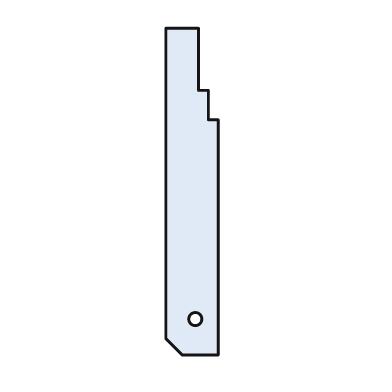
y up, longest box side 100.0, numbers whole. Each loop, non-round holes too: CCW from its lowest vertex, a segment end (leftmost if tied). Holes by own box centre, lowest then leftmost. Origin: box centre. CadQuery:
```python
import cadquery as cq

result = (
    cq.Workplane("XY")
    .moveTo(-3.0, -50.0)
    .lineTo(8.0, -50.0)
    .lineTo(8.0, 22.0)
    .lineTo(5.0, 22.0)
    .lineTo(5.0, 31.0)
    .lineTo(2.0, 31.0)
    .lineTo(2.0, 50.0)
    .lineTo(-8.0, 50.0)
    .lineTo(-8.0, -45.0)
    .close()
    .moveTo(1.0, -39.0)
    .circle(2.0)
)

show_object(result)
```